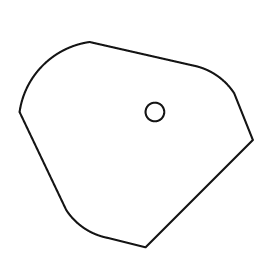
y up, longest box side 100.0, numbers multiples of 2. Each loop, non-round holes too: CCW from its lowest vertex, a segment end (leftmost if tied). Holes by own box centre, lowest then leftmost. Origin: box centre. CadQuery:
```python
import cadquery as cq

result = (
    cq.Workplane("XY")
    .moveTo(4.0, -44.0)
    .lineTo(50.0, 2.0)
    .lineTo(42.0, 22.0)
    .threePointArc((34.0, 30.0), (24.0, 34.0))
    .lineTo(-20.0, 44.0)
    .threePointArc((-40.0, 34.0), (-50.0, 14.0))
    .lineTo(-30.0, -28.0)
    .threePointArc((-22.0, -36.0), (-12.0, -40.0))
    .close()
    .moveTo(8.0, 14.0)
    .circle(4.0)
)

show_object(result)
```